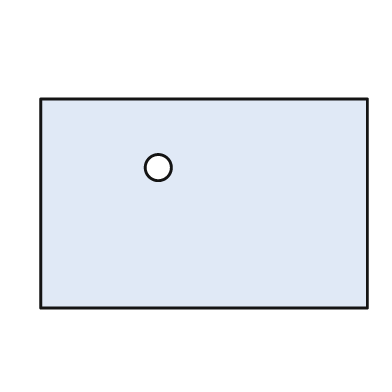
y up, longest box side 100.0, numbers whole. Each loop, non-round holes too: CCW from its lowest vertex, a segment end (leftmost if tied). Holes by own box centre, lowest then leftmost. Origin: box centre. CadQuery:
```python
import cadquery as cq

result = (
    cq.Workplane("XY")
    .moveTo(-50.0, -32.0)
    .lineTo(50.0, -32.0)
    .lineTo(50.0, 32.0)
    .lineTo(-50.0, 32.0)
    .close()
    .moveTo(-14.0, 11.0)
    .circle(4.0)
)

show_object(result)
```